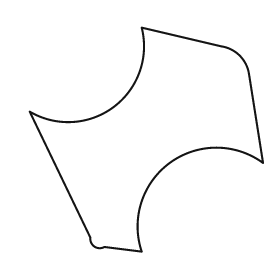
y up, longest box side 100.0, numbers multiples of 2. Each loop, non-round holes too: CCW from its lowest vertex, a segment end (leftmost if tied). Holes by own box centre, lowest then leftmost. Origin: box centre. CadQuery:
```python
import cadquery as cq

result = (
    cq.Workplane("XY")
    .moveTo(-2.0, -48.0)
    .threePointArc((10.0, -10.0), (50.0, -10.0))
    .lineTo(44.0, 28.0)
    .threePointArc((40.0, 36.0), (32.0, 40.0))
    .lineTo(-2.0, 48.0)
    .threePointArc((-14.0, 14.0), (-50.0, 12.0))
    .lineTo(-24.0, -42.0)
    .threePointArc((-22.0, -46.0), (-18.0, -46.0))
    .close()
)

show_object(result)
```